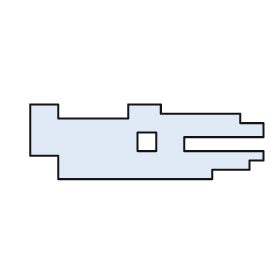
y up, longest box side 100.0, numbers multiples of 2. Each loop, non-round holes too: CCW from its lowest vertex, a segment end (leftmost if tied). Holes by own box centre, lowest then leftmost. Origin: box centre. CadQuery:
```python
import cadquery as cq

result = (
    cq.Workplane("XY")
    .moveTo(-38.0, -16.0)
    .lineTo(28.0, -16.0)
    .lineTo(28.0, -12.0)
    .lineTo(44.0, -12.0)
    .lineTo(44.0, -8.0)
    .lineTo(50.0, -8.0)
    .lineTo(50.0, -4.0)
    .lineTo(16.0, -4.0)
    .lineTo(16.0, 2.0)
    .lineTo(50.0, 2.0)
    .lineTo(50.0, 8.0)
    .lineTo(40.0, 8.0)
    .lineTo(40.0, 12.0)
    .lineTo(6.0, 12.0)
    .lineTo(6.0, 16.0)
    .lineTo(-8.0, 16.0)
    .lineTo(-8.0, 10.0)
    .lineTo(-38.0, 10.0)
    .lineTo(-38.0, 16.0)
    .lineTo(-50.0, 16.0)
    .lineTo(-50.0, -6.0)
    .lineTo(-38.0, -6.0)
    .close()
    .moveTo(-4.0, -4.0)
    .lineTo(4.0, -4.0)
    .lineTo(4.0, 4.0)
    .lineTo(-4.0, 4.0)
    .close()
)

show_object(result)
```